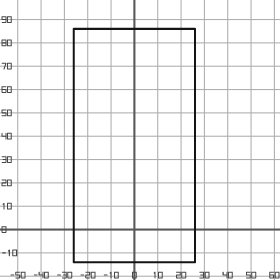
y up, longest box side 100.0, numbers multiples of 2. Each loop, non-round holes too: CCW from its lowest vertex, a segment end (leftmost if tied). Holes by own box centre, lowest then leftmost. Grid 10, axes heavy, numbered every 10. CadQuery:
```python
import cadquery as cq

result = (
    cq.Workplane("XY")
    .moveTo(-26.0, -14.0)
    .lineTo(26.0, -14.0)
    .lineTo(26.0, 86.0)
    .lineTo(-26.0, 86.0)
    .close()
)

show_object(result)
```